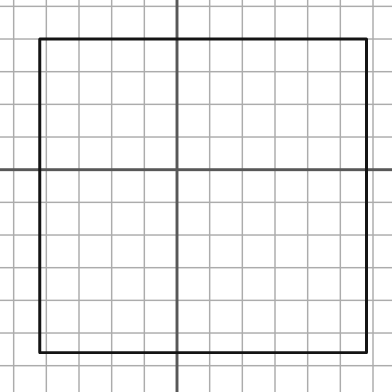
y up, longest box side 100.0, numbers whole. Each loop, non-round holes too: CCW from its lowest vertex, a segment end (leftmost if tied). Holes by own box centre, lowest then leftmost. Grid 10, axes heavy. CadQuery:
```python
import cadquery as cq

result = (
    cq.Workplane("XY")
    .moveTo(-42.0, -56.0)
    .lineTo(58.0, -56.0)
    .lineTo(58.0, 40.0)
    .lineTo(-42.0, 40.0)
    .close()
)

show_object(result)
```